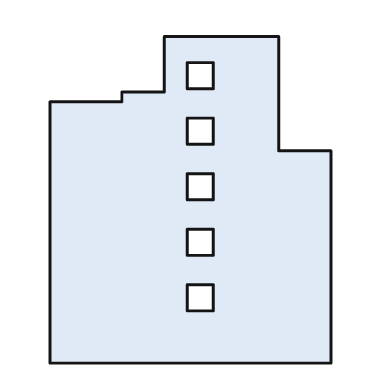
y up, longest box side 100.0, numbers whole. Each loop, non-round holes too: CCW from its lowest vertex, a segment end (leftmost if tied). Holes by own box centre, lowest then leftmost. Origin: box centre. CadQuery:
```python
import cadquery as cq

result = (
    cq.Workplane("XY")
    .moveTo(-43.0, -50.0)
    .lineTo(43.0, -50.0)
    .lineTo(43.0, 15.0)
    .lineTo(27.0, 15.0)
    .lineTo(27.0, 50.0)
    .lineTo(-8.0, 50.0)
    .lineTo(-8.0, 33.0)
    .lineTo(-21.0, 33.0)
    .lineTo(-21.0, 30.0)
    .lineTo(-43.0, 30.0)
    .close()
    .moveTo(-1.0, -34.0)
    .lineTo(7.0, -34.0)
    .lineTo(7.0, -26.0)
    .lineTo(-1.0, -26.0)
    .close()
    .moveTo(-1.0, -17.0)
    .lineTo(7.0, -17.0)
    .lineTo(7.0, -9.0)
    .lineTo(-1.0, -9.0)
    .close()
    .moveTo(-1.0, 0.0)
    .lineTo(7.0, 0.0)
    .lineTo(7.0, 8.0)
    .lineTo(-1.0, 8.0)
    .close()
    .moveTo(-1.0, 17.0)
    .lineTo(7.0, 17.0)
    .lineTo(7.0, 25.0)
    .lineTo(-1.0, 25.0)
    .close()
    .moveTo(-1.0, 34.0)
    .lineTo(7.0, 34.0)
    .lineTo(7.0, 42.0)
    .lineTo(-1.0, 42.0)
    .close()
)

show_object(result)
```